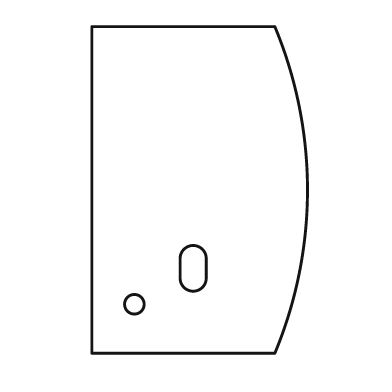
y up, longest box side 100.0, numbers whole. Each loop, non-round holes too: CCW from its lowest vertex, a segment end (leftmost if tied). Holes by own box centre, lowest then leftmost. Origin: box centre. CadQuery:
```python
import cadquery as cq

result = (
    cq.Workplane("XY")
    .moveTo(-33.0, -50.0)
    .lineTo(23.0, -50.0)
    .threePointArc((33.0, 0.0), (23.0, 50.0))
    .lineTo(-33.0, 50.0)
    .close()
    .moveTo(-20.0, -35.0)
    .circle(3.0)
    .moveTo(-6.0, -27.0)
    .threePointArc((-2.0, -31.0), (2.0, -27.0))
    .lineTo(2.0, -21.0)
    .threePointArc((-2.0, -17.0), (-6.0, -21.0))
    .close()
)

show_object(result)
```